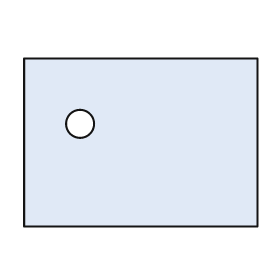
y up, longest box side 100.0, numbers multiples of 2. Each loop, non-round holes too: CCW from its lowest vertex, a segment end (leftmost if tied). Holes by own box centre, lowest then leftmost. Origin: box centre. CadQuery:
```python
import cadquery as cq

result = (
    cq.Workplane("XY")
    .moveTo(-50.0, -36.0)
    .lineTo(50.0, -36.0)
    .lineTo(50.0, 36.0)
    .lineTo(-50.0, 36.0)
    .close()
    .moveTo(-26.0, 8.0)
    .circle(6.0)
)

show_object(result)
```